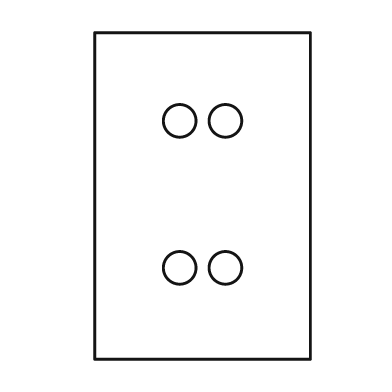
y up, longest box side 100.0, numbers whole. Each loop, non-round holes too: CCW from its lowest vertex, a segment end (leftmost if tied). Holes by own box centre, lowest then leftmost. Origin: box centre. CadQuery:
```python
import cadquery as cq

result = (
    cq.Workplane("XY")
    .moveTo(-33.0, -50.0)
    .lineTo(33.0, -50.0)
    .lineTo(33.0, 50.0)
    .lineTo(-33.0, 50.0)
    .close()
    .moveTo(-7.0, -22.0)
    .circle(5.0)
    .moveTo(7.0, -22.0)
    .circle(5.0)
    .moveTo(-7.0, 23.0)
    .circle(5.0)
    .moveTo(7.0, 23.0)
    .circle(5.0)
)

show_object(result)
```